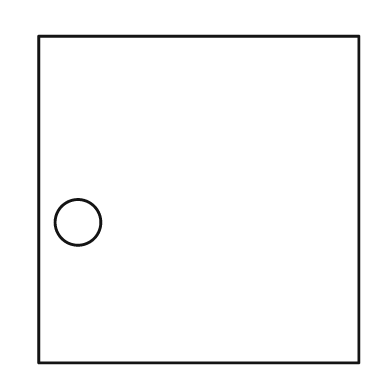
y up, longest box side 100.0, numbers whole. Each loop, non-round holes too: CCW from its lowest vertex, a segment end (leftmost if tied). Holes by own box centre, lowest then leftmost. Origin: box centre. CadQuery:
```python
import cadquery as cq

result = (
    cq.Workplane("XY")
    .moveTo(-49.0, -50.0)
    .lineTo(49.0, -50.0)
    .lineTo(49.0, 50.0)
    .lineTo(-49.0, 50.0)
    .close()
    .moveTo(-37.0, -7.0)
    .circle(7.0)
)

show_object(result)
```